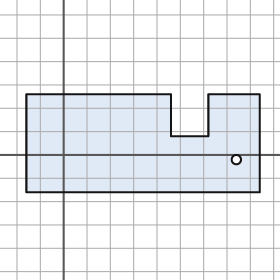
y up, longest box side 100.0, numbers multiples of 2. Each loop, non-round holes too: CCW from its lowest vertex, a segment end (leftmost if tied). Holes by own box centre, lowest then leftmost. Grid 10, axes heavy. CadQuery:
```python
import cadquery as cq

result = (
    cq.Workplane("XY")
    .moveTo(-16.0, -16.0)
    .lineTo(84.0, -16.0)
    .lineTo(84.0, 26.0)
    .lineTo(62.0, 26.0)
    .lineTo(62.0, 8.0)
    .lineTo(46.0, 8.0)
    .lineTo(46.0, 26.0)
    .lineTo(-16.0, 26.0)
    .close()
    .moveTo(74.0, -2.0)
    .circle(2.0)
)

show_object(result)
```